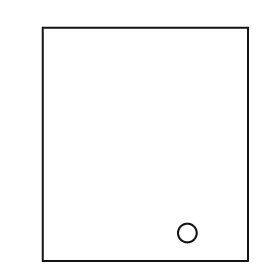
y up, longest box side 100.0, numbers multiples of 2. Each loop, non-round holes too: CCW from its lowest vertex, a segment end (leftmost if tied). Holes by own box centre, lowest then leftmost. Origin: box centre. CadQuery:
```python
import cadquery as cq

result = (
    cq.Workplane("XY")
    .moveTo(-44.0, -50.0)
    .lineTo(44.0, -50.0)
    .lineTo(44.0, 50.0)
    .lineTo(-44.0, 50.0)
    .close()
    .moveTo(18.0, -38.0)
    .circle(4.0)
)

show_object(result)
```